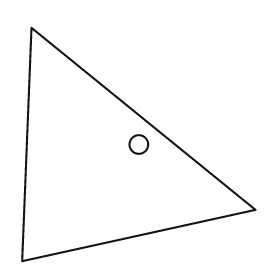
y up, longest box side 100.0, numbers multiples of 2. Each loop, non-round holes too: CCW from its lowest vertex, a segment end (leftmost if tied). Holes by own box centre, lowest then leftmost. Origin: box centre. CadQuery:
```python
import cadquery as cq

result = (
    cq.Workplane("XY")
    .moveTo(-50.0, -50.0)
    .lineTo(50.0, -28.0)
    .lineTo(-46.0, 50.0)
    .close()
    .moveTo(0.0, 0.0)
    .circle(4.0)
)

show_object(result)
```